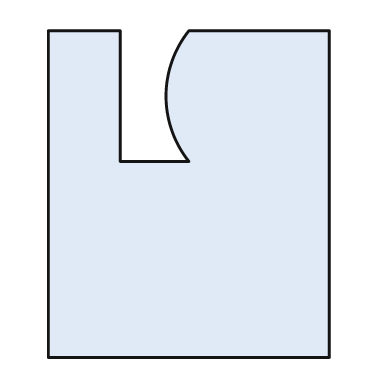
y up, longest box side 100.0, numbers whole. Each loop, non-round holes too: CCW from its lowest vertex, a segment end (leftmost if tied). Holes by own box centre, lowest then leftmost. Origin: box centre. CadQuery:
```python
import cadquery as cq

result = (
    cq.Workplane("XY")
    .moveTo(-43.0, -50.0)
    .lineTo(43.0, -50.0)
    .lineTo(43.0, 50.0)
    .lineTo(0.0, 50.0)
    .threePointArc((-7.0, 30.0), (0.0, 10.0))
    .lineTo(-21.0, 10.0)
    .lineTo(-21.0, 50.0)
    .lineTo(-43.0, 50.0)
    .close()
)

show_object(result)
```